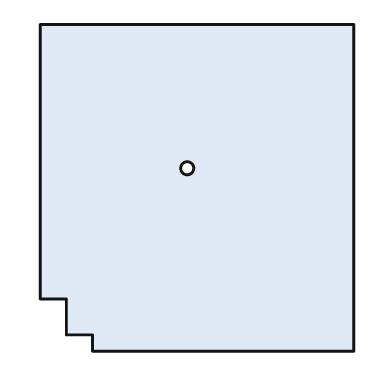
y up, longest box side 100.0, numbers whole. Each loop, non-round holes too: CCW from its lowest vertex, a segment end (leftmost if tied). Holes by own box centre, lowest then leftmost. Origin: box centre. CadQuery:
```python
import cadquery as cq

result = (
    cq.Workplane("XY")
    .moveTo(-32.0, -50.0)
    .lineTo(48.0, -50.0)
    .lineTo(48.0, 50.0)
    .lineTo(-48.0, 50.0)
    .lineTo(-48.0, -34.0)
    .lineTo(-40.0, -34.0)
    .lineTo(-40.0, -45.0)
    .lineTo(-32.0, -45.0)
    .close()
    .moveTo(-3.0, 6.0)
    .circle(2.0)
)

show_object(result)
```